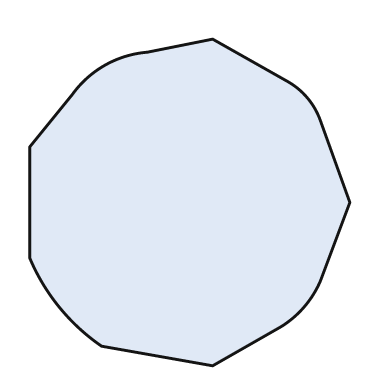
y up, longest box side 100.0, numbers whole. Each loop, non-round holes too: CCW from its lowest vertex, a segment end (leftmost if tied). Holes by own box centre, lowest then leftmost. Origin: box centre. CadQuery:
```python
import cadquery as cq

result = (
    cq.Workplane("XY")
    .moveTo(7.0, -50.0)
    .lineTo(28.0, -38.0)
    .threePointArc((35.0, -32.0), (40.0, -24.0))
    .lineTo(49.0, 0.0)
    .lineTo(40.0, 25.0)
    .threePointArc((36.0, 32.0), (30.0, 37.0))
    .lineTo(7.0, 50.0)
    .lineTo(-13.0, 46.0)
    .threePointArc((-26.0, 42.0), (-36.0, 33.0))
    .lineTo(-49.0, 17.0)
    .lineTo(-49.0, -17.0)
    .threePointArc((-40.0, -32.0), (-27.0, -44.0))
    .close()
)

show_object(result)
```